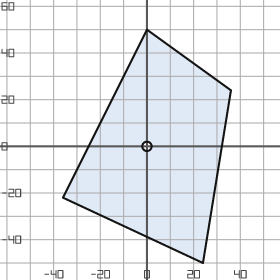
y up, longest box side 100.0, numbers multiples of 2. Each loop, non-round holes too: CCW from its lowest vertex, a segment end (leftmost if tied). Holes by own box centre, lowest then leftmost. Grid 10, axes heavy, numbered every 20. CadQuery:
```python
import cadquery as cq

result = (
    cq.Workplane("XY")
    .moveTo(24.0, -50.0)
    .lineTo(36.0, 24.0)
    .lineTo(0.0, 50.0)
    .lineTo(-36.0, -22.0)
    .close()
    .moveTo(0.0, 0.0)
    .circle(2.0)
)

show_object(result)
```